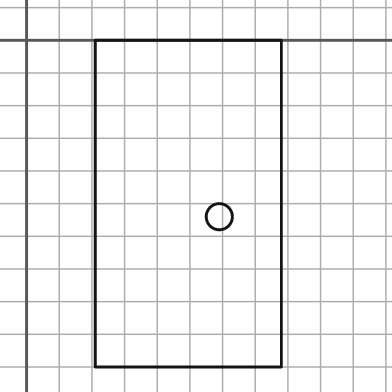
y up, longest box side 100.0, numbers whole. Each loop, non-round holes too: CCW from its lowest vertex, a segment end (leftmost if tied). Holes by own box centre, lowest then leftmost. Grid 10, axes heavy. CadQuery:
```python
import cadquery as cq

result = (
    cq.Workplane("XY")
    .moveTo(21.0, -100.0)
    .lineTo(78.0, -100.0)
    .lineTo(78.0, 0.0)
    .lineTo(21.0, 0.0)
    .close()
    .moveTo(59.0, -54.0)
    .circle(4.0)
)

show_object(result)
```